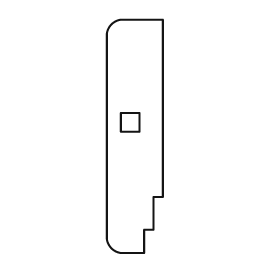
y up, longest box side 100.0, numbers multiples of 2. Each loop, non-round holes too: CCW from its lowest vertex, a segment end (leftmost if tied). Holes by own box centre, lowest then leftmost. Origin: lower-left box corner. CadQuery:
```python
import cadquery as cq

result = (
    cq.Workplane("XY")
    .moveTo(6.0, 0.0)
    .lineTo(16.0, 0.0)
    .lineTo(16.0, 10.0)
    .lineTo(20.0, 10.0)
    .lineTo(20.0, 24.0)
    .lineTo(24.0, 24.0)
    .lineTo(24.0, 100.0)
    .lineTo(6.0, 100.0)
    .threePointArc((2.0, 98.0), (0.0, 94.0))
    .lineTo(0.0, 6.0)
    .threePointArc((2.0, 2.0), (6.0, 0.0))
    .close()
    .moveTo(6.0, 52.0)
    .lineTo(14.0, 52.0)
    .lineTo(14.0, 60.0)
    .lineTo(6.0, 60.0)
    .close()
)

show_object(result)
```